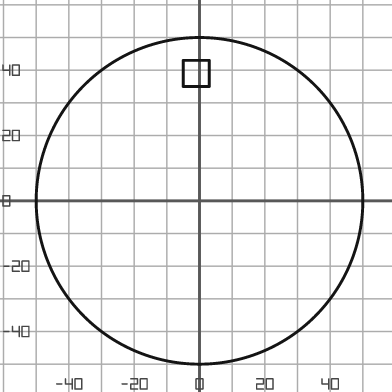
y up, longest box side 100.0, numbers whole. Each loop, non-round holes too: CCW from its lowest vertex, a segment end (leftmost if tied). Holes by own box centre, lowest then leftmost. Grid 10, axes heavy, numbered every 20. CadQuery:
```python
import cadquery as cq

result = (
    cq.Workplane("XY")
    .moveTo(0.0, 0.0)
    .circle(50.0)
    .moveTo(-5.0, 35.0)
    .lineTo(3.0, 35.0)
    .lineTo(3.0, 43.0)
    .lineTo(-5.0, 43.0)
    .close()
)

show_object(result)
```